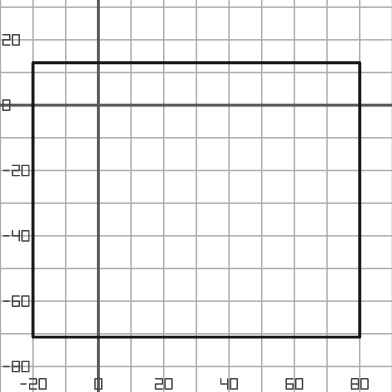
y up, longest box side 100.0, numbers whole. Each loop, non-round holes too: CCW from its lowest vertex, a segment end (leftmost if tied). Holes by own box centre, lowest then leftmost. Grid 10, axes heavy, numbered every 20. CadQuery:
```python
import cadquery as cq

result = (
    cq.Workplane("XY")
    .moveTo(-20.0, -71.0)
    .lineTo(80.0, -71.0)
    .lineTo(80.0, 13.0)
    .lineTo(-20.0, 13.0)
    .close()
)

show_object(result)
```